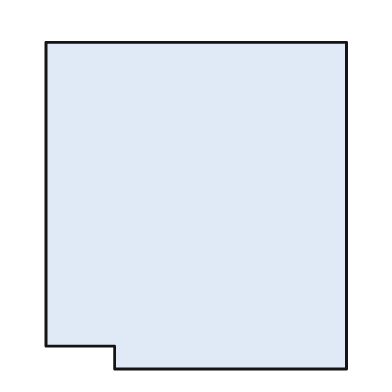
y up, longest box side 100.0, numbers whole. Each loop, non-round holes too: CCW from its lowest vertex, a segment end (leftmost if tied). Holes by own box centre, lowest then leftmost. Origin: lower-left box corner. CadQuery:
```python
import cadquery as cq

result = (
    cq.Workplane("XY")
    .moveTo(21.0, 0.0)
    .lineTo(92.0, 0.0)
    .lineTo(92.0, 100.0)
    .lineTo(0.0, 100.0)
    .lineTo(0.0, 7.0)
    .lineTo(21.0, 7.0)
    .close()
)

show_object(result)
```